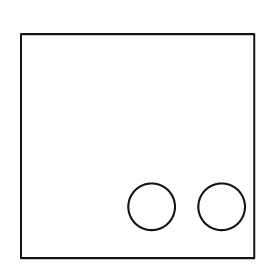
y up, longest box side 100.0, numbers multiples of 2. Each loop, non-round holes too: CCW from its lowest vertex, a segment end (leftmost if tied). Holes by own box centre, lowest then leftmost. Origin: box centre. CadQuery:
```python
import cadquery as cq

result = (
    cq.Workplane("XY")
    .moveTo(-50.0, -48.0)
    .lineTo(50.0, -48.0)
    .lineTo(50.0, 48.0)
    .lineTo(-50.0, 48.0)
    .close()
    .moveTo(6.0, -26.0)
    .circle(10.0)
    .moveTo(36.0, -26.0)
    .circle(10.0)
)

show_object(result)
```